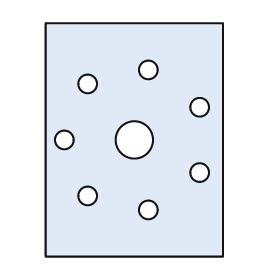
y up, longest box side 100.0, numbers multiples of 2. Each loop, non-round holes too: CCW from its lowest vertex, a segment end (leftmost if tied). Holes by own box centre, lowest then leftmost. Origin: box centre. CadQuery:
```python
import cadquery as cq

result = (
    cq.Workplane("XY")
    .moveTo(-38.0, -50.0)
    .lineTo(38.0, -50.0)
    .lineTo(38.0, 50.0)
    .lineTo(-38.0, 50.0)
    .close()
    .moveTo(6.0, -30.0)
    .circle(4.0)
    .moveTo(-20.0, -24.0)
    .circle(4.0)
    .moveTo(28.0, -14.0)
    .circle(4.0)
    .moveTo(-30.0, 0.0)
    .circle(4.0)
    .moveTo(0.0, 0.0)
    .circle(8.0)
    .moveTo(28.0, 14.0)
    .circle(4.0)
    .moveTo(-20.0, 24.0)
    .circle(4.0)
    .moveTo(6.0, 30.0)
    .circle(4.0)
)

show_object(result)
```